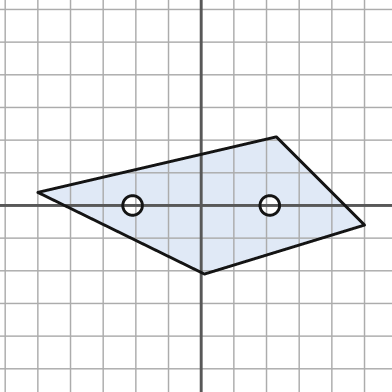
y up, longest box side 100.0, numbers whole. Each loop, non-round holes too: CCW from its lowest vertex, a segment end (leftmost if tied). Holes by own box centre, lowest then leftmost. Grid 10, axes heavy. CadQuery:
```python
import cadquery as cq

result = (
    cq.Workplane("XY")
    .moveTo(1.0, -21.0)
    .lineTo(50.0, -6.0)
    .lineTo(23.0, 21.0)
    .lineTo(-50.0, 4.0)
    .close()
    .moveTo(-21.0, 0.0)
    .circle(3.0)
    .moveTo(21.0, 0.0)
    .circle(3.0)
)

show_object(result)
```